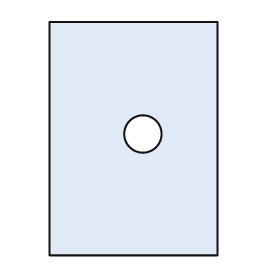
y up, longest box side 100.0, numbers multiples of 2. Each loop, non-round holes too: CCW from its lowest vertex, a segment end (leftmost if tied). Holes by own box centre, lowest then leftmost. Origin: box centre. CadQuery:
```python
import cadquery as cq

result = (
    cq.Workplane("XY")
    .moveTo(-36.0, -50.0)
    .lineTo(36.0, -50.0)
    .lineTo(36.0, 50.0)
    .lineTo(-36.0, 50.0)
    .close()
    .moveTo(4.0, 2.0)
    .circle(8.0)
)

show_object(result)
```